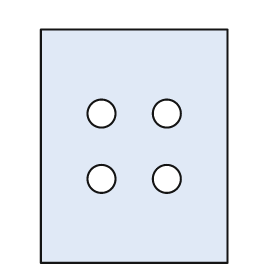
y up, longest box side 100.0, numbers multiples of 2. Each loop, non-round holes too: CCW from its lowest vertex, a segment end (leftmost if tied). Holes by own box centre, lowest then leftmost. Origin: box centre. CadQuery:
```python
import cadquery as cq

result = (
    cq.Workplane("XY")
    .moveTo(-40.0, -50.0)
    .lineTo(40.0, -50.0)
    .lineTo(40.0, 50.0)
    .lineTo(-40.0, 50.0)
    .close()
    .moveTo(-14.0, -14.0)
    .circle(6.0)
    .moveTo(14.0, -14.0)
    .circle(6.0)
    .moveTo(-14.0, 14.0)
    .circle(6.0)
    .moveTo(14.0, 14.0)
    .circle(6.0)
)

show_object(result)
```